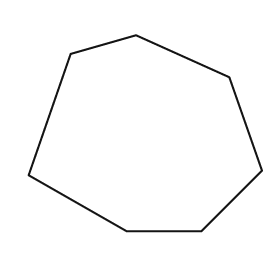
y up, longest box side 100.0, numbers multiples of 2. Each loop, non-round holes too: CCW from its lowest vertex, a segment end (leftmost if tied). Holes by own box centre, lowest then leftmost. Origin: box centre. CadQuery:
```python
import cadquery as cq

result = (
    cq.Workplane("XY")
    .moveTo(-8.0, -42.0)
    .lineTo(24.0, -42.0)
    .lineTo(50.0, -16.0)
    .lineTo(36.0, 24.0)
    .lineTo(-4.0, 42.0)
    .lineTo(-32.0, 34.0)
    .lineTo(-50.0, -18.0)
    .close()
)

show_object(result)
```